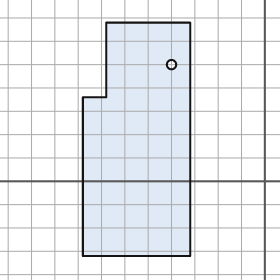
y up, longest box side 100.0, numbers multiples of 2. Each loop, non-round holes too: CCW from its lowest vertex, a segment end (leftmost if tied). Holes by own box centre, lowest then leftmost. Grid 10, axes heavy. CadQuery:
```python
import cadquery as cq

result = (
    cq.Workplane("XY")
    .moveTo(-78.0, -32.0)
    .lineTo(-32.0, -32.0)
    .lineTo(-32.0, 68.0)
    .lineTo(-68.0, 68.0)
    .lineTo(-68.0, 36.0)
    .lineTo(-78.0, 36.0)
    .close()
    .moveTo(-40.0, 50.0)
    .circle(2.0)
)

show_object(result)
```